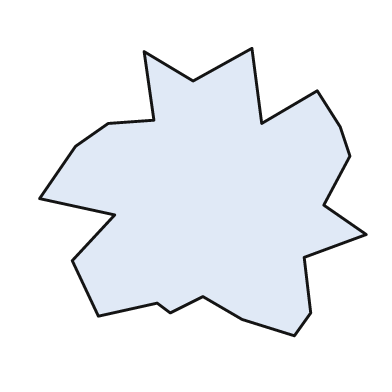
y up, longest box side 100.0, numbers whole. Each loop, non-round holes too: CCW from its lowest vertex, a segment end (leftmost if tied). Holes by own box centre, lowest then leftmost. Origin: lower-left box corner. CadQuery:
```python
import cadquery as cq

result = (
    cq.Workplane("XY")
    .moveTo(78.0, 0.0)
    .lineTo(83.0, 7.0)
    .lineTo(81.0, 24.0)
    .lineTo(100.0, 31.0)
    .lineTo(87.0, 40.0)
    .lineTo(95.0, 55.0)
    .lineTo(92.0, 64.0)
    .lineTo(85.0, 75.0)
    .lineTo(68.0, 65.0)
    .lineTo(65.0, 88.0)
    .lineTo(47.0, 78.0)
    .lineTo(32.0, 87.0)
    .lineTo(35.0, 66.0)
    .lineTo(21.0, 65.0)
    .lineTo(11.0, 58.0)
    .lineTo(0.0, 42.0)
    .lineTo(23.0, 37.0)
    .lineTo(10.0, 23.0)
    .lineTo(18.0, 6.0)
    .lineTo(36.0, 10.0)
    .lineTo(40.0, 7.0)
    .lineTo(50.0, 12.0)
    .lineTo(62.0, 5.0)
    .close()
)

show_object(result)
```